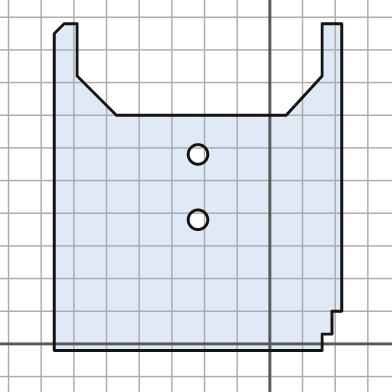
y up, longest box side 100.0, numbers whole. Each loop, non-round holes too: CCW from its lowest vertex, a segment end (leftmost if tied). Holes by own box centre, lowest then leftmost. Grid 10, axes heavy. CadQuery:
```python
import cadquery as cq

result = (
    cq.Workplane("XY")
    .moveTo(-66.0, -2.0)
    .lineTo(16.0, -2.0)
    .lineTo(16.0, 3.0)
    .lineTo(19.0, 3.0)
    .lineTo(19.0, 10.0)
    .lineTo(22.0, 10.0)
    .lineTo(22.0, 98.0)
    .lineTo(16.0, 98.0)
    .lineTo(16.0, 82.0)
    .lineTo(5.0, 70.0)
    .lineTo(-47.0, 70.0)
    .lineTo(-59.0, 82.0)
    .lineTo(-59.0, 98.0)
    .lineTo(-63.0, 98.0)
    .lineTo(-66.0, 95.0)
    .close()
    .moveTo(-22.0, 38.0)
    .circle(3.0)
    .moveTo(-22.0, 58.0)
    .circle(3.0)
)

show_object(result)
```